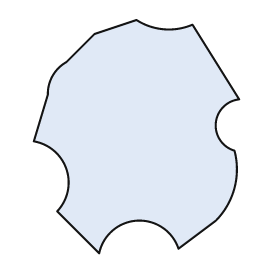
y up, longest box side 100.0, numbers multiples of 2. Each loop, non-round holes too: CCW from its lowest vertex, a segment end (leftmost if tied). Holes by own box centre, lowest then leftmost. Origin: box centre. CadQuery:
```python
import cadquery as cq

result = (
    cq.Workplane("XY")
    .moveTo(-16.0, -50.0)
    .threePointArc((0.0, -36.0), (18.0, -48.0))
    .lineTo(34.0, -36.0)
    .threePointArc((42.0, -22.0), (42.0, -6.0))
    .threePointArc((34.0, 6.0), (44.0, 16.0))
    .lineTo(24.0, 48.0)
    .threePointArc((12.0, 46.0), (0.0, 50.0))
    .lineTo(-18.0, 44.0)
    .lineTo(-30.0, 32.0)
    .threePointArc((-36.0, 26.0), (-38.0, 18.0))
    .lineTo(-44.0, -2.0)
    .threePointArc((-30.0, -14.0), (-34.0, -32.0))
    .close()
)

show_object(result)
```